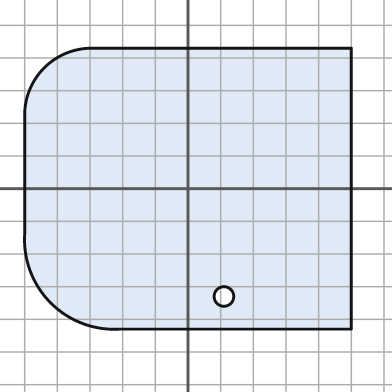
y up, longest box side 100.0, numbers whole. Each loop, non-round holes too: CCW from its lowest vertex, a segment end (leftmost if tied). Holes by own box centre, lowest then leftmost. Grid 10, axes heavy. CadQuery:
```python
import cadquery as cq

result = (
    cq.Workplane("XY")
    .moveTo(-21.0, -43.0)
    .lineTo(50.0, -43.0)
    .lineTo(50.0, 43.0)
    .lineTo(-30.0, 43.0)
    .threePointArc((-44.0, 37.0), (-50.0, 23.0))
    .lineTo(-50.0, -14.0)
    .threePointArc((-42.0, -35.0), (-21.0, -43.0))
    .close()
    .moveTo(11.0, -33.0)
    .circle(3.0)
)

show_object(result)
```